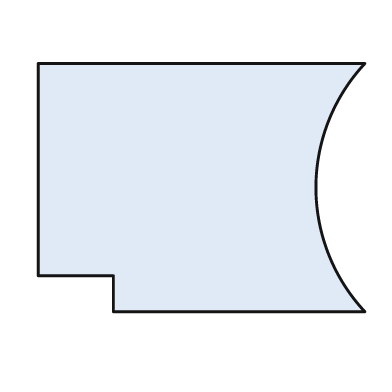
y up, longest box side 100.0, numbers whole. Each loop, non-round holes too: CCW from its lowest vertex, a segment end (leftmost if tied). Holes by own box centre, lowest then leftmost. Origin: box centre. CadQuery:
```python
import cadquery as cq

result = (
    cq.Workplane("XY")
    .moveTo(-27.0, -38.0)
    .lineTo(50.0, -38.0)
    .threePointArc((35.0, 0.0), (50.0, 38.0))
    .lineTo(-50.0, 38.0)
    .lineTo(-50.0, -27.0)
    .lineTo(-27.0, -27.0)
    .close()
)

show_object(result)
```